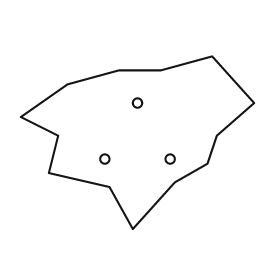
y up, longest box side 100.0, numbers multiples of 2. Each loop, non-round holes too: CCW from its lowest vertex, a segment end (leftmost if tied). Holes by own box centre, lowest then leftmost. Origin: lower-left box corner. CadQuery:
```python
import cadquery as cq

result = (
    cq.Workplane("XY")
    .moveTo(48.0, 0.0)
    .lineTo(66.0, 20.0)
    .lineTo(80.0, 28.0)
    .lineTo(84.0, 40.0)
    .lineTo(100.0, 54.0)
    .lineTo(82.0, 74.0)
    .lineTo(60.0, 68.0)
    .lineTo(42.0, 68.0)
    .lineTo(20.0, 62.0)
    .lineTo(0.0, 48.0)
    .lineTo(16.0, 40.0)
    .lineTo(12.0, 24.0)
    .lineTo(38.0, 18.0)
    .close()
    .moveTo(36.0, 30.0)
    .circle(2.0)
    .moveTo(64.0, 30.0)
    .circle(2.0)
    .moveTo(50.0, 54.0)
    .circle(2.0)
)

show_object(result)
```